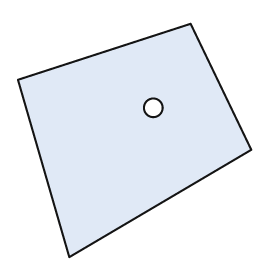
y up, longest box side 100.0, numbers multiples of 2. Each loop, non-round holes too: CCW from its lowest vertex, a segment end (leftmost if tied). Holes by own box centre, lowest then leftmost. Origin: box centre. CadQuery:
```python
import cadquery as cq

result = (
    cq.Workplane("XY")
    .moveTo(-28.0, -50.0)
    .lineTo(50.0, -4.0)
    .lineTo(24.0, 50.0)
    .lineTo(-50.0, 26.0)
    .close()
    .moveTo(8.0, 14.0)
    .circle(4.0)
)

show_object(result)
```